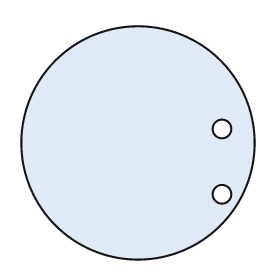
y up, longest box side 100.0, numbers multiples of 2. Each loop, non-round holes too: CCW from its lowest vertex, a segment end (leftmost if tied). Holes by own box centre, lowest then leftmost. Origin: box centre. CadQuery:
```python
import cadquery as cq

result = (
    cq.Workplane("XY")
    .moveTo(0.0, 0.0)
    .circle(50.0)
    .moveTo(36.0, -22.0)
    .circle(4.0)
    .moveTo(36.0, 6.0)
    .circle(4.0)
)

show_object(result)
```